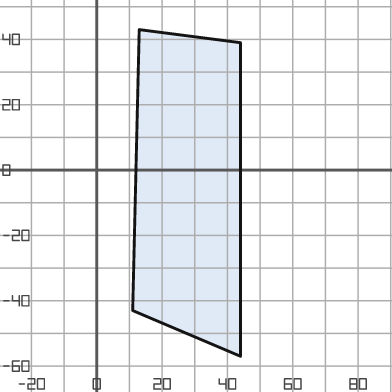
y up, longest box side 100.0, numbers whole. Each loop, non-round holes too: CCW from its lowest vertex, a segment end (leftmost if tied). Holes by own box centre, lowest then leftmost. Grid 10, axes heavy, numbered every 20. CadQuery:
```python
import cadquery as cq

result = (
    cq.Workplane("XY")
    .moveTo(44.0, -57.0)
    .lineTo(44.0, 39.0)
    .lineTo(13.0, 43.0)
    .lineTo(11.0, -43.0)
    .close()
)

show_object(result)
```